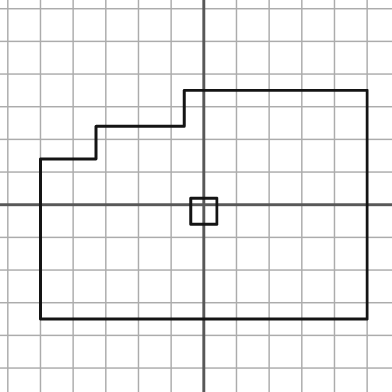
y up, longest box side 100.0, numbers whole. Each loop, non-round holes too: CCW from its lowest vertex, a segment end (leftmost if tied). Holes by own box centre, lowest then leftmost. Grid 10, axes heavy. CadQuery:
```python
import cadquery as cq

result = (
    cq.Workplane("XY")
    .moveTo(-50.0, -35.0)
    .lineTo(50.0, -35.0)
    .lineTo(50.0, 35.0)
    .lineTo(-6.0, 35.0)
    .lineTo(-6.0, 24.0)
    .lineTo(-33.0, 24.0)
    .lineTo(-33.0, 14.0)
    .lineTo(-50.0, 14.0)
    .close()
    .moveTo(-4.0, -6.0)
    .lineTo(4.0, -6.0)
    .lineTo(4.0, 2.0)
    .lineTo(-4.0, 2.0)
    .close()
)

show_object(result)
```